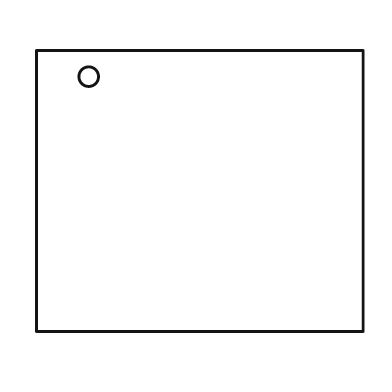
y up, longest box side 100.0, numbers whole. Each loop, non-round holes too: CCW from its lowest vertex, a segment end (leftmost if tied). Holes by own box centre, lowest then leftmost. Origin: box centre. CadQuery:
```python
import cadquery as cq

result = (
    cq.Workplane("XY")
    .moveTo(-50.0, -43.0)
    .lineTo(50.0, -43.0)
    .lineTo(50.0, 43.0)
    .lineTo(-50.0, 43.0)
    .close()
    .moveTo(-34.0, 35.0)
    .circle(3.0)
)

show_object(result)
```